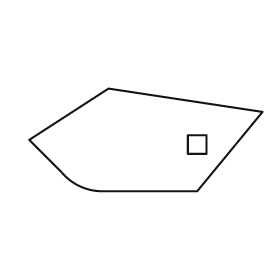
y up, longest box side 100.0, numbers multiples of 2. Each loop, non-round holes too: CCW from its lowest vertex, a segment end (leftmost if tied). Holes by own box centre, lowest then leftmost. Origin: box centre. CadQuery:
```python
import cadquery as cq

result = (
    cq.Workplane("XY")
    .moveTo(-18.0, -22.0)
    .lineTo(22.0, -22.0)
    .lineTo(50.0, 12.0)
    .lineTo(-16.0, 22.0)
    .lineTo(-50.0, 0.0)
    .lineTo(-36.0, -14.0)
    .threePointArc((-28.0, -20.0), (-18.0, -22.0))
    .close()
    .moveTo(18.0, -6.0)
    .lineTo(26.0, -6.0)
    .lineTo(26.0, 2.0)
    .lineTo(18.0, 2.0)
    .close()
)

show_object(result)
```